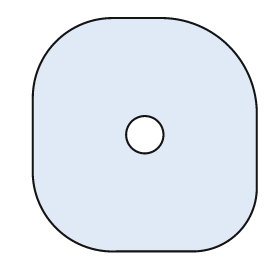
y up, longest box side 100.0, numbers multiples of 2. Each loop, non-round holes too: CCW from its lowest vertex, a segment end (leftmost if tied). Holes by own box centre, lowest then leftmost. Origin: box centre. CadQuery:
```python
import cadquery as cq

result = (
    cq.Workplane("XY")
    .moveTo(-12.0, -50.0)
    .lineTo(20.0, -50.0)
    .threePointArc((40.0, -42.0), (48.0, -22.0))
    .lineTo(48.0, 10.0)
    .threePointArc((36.0, 38.0), (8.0, 50.0))
    .lineTo(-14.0, 50.0)
    .threePointArc((-38.0, 40.0), (-48.0, 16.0))
    .lineTo(-48.0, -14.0)
    .threePointArc((-38.0, -40.0), (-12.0, -50.0))
    .close()
    .moveTo(0.0, 0.0)
    .circle(8.0)
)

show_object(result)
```